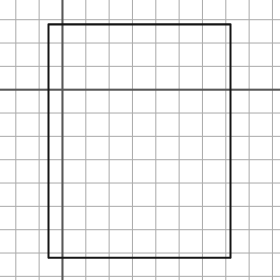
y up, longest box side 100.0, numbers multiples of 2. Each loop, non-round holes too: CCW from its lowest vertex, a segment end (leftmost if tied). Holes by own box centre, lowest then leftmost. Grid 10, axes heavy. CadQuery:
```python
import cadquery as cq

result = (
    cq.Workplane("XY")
    .moveTo(-6.0, -72.0)
    .lineTo(72.0, -72.0)
    .lineTo(72.0, 28.0)
    .lineTo(-6.0, 28.0)
    .close()
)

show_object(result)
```